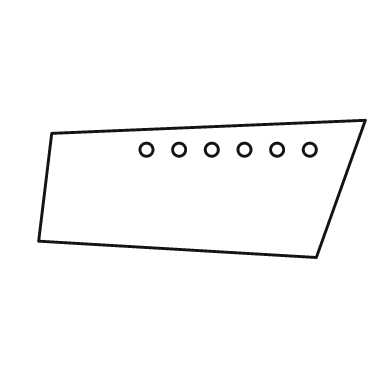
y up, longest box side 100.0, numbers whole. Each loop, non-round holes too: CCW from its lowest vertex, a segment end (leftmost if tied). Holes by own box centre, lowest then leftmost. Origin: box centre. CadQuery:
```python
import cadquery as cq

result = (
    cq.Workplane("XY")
    .moveTo(35.0, -21.0)
    .lineTo(50.0, 21.0)
    .lineTo(-46.0, 17.0)
    .lineTo(-50.0, -16.0)
    .close()
    .moveTo(-17.0, 12.0)
    .circle(2.0)
    .moveTo(-7.0, 12.0)
    .circle(2.0)
    .moveTo(3.0, 12.0)
    .circle(2.0)
    .moveTo(13.0, 12.0)
    .circle(2.0)
    .moveTo(23.0, 12.0)
    .circle(2.0)
    .moveTo(33.0, 12.0)
    .circle(2.0)
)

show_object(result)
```